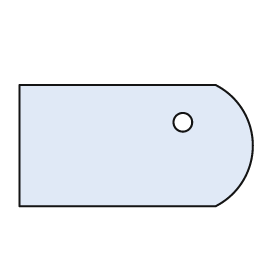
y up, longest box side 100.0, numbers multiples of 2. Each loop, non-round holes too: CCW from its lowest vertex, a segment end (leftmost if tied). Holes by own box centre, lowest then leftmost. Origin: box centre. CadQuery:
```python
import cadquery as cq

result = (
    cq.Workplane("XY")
    .moveTo(-50.0, -26.0)
    .lineTo(34.0, -26.0)
    .threePointArc((50.0, 0.0), (34.0, 26.0))
    .lineTo(-50.0, 26.0)
    .close()
    .moveTo(20.0, 10.0)
    .circle(4.0)
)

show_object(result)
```